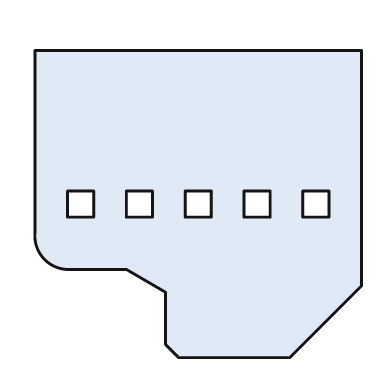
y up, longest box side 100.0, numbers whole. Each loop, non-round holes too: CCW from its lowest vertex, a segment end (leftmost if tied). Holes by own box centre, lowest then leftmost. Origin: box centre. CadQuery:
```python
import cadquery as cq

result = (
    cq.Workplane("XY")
    .moveTo(-6.0, -47.0)
    .lineTo(28.0, -47.0)
    .lineTo(50.0, -25.0)
    .lineTo(50.0, 47.0)
    .lineTo(-50.0, 47.0)
    .lineTo(-50.0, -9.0)
    .threePointArc((-47.0, -17.0), (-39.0, -20.0))
    .lineTo(-22.0, -20.0)
    .lineTo(-10.0, -27.0)
    .lineTo(-10.0, -43.0)
    .close()
    .moveTo(-40.0, -4.0)
    .lineTo(-32.0, -4.0)
    .lineTo(-32.0, 4.0)
    .lineTo(-40.0, 4.0)
    .close()
    .moveTo(-22.0, -4.0)
    .lineTo(-14.0, -4.0)
    .lineTo(-14.0, 4.0)
    .lineTo(-22.0, 4.0)
    .close()
    .moveTo(-4.0, -4.0)
    .lineTo(4.0, -4.0)
    .lineTo(4.0, 4.0)
    .lineTo(-4.0, 4.0)
    .close()
    .moveTo(14.0, -4.0)
    .lineTo(22.0, -4.0)
    .lineTo(22.0, 4.0)
    .lineTo(14.0, 4.0)
    .close()
    .moveTo(32.0, -4.0)
    .lineTo(40.0, -4.0)
    .lineTo(40.0, 4.0)
    .lineTo(32.0, 4.0)
    .close()
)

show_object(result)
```